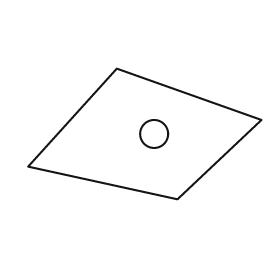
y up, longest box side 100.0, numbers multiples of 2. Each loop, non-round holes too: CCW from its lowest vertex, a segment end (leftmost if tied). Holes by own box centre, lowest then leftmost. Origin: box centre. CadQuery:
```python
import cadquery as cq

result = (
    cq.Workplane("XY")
    .moveTo(14.0, -28.0)
    .lineTo(50.0, 6.0)
    .lineTo(-12.0, 28.0)
    .lineTo(-50.0, -14.0)
    .close()
    .moveTo(4.0, 0.0)
    .circle(6.0)
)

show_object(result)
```